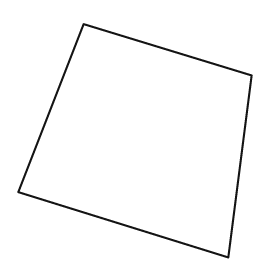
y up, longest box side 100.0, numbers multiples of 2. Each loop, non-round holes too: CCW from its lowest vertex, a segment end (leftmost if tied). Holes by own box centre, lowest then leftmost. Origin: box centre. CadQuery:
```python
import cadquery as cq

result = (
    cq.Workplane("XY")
    .moveTo(40.0, -50.0)
    .lineTo(50.0, 28.0)
    .lineTo(-22.0, 50.0)
    .lineTo(-50.0, -22.0)
    .close()
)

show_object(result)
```